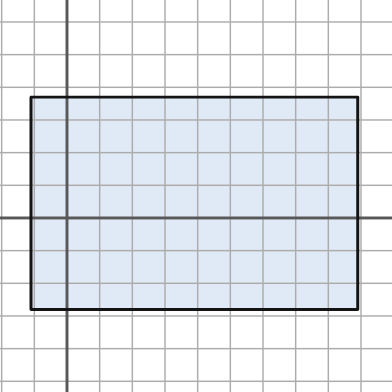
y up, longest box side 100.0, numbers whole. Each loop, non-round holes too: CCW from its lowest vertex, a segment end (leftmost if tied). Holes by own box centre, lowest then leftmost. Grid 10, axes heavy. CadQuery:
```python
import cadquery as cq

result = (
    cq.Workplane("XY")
    .moveTo(-11.0, -28.0)
    .lineTo(89.0, -28.0)
    .lineTo(89.0, 37.0)
    .lineTo(-11.0, 37.0)
    .close()
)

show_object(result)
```